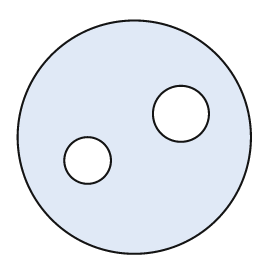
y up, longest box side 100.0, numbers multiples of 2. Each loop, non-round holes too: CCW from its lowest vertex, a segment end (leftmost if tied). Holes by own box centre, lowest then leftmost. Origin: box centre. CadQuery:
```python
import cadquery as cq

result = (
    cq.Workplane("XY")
    .moveTo(0.0, 0.0)
    .circle(50.0)
    .moveTo(-20.0, -10.0)
    .circle(10.0)
    .moveTo(20.0, 10.0)
    .circle(12.0)
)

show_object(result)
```